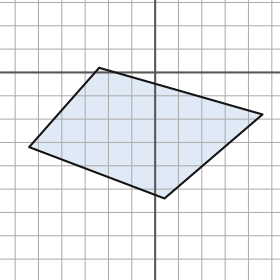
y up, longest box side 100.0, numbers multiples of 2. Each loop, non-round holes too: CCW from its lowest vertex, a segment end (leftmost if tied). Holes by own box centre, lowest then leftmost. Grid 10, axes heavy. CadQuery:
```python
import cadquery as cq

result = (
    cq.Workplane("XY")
    .moveTo(4.0, -54.0)
    .lineTo(46.0, -18.0)
    .lineTo(-24.0, 2.0)
    .lineTo(-54.0, -32.0)
    .close()
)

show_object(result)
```